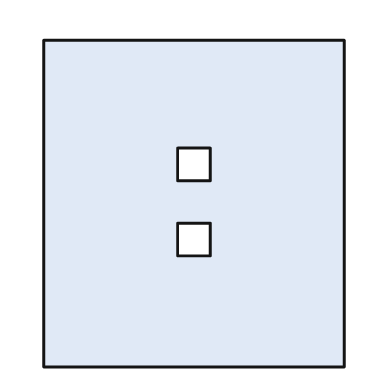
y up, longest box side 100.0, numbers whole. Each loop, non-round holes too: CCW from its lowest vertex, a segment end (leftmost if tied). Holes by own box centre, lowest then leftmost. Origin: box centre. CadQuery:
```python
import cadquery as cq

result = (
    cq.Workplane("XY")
    .moveTo(-46.0, -50.0)
    .lineTo(46.0, -50.0)
    .lineTo(46.0, 50.0)
    .lineTo(-46.0, 50.0)
    .close()
    .moveTo(-5.0, -16.0)
    .lineTo(5.0, -16.0)
    .lineTo(5.0, -6.0)
    .lineTo(-5.0, -6.0)
    .close()
    .moveTo(-5.0, 7.0)
    .lineTo(5.0, 7.0)
    .lineTo(5.0, 17.0)
    .lineTo(-5.0, 17.0)
    .close()
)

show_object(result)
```